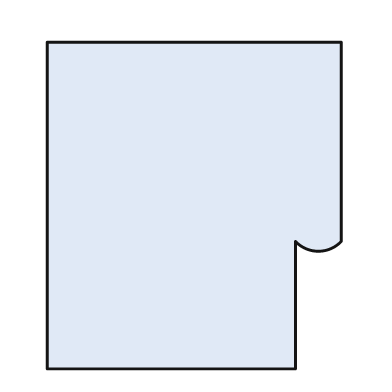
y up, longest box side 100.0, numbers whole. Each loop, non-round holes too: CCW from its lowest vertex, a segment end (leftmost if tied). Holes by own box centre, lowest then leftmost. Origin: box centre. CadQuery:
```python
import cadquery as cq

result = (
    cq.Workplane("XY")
    .moveTo(-45.0, -50.0)
    .lineTo(31.0, -50.0)
    .lineTo(31.0, -11.0)
    .threePointArc((38.0, -14.0), (45.0, -11.0))
    .lineTo(45.0, 50.0)
    .lineTo(-45.0, 50.0)
    .close()
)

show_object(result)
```